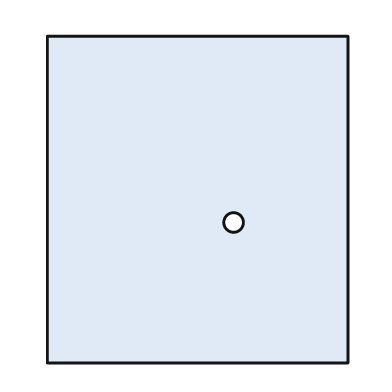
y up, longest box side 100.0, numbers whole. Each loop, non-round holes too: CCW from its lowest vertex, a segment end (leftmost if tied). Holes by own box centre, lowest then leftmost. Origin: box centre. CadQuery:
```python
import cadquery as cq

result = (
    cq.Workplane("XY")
    .moveTo(-46.0, -50.0)
    .lineTo(46.0, -50.0)
    .lineTo(46.0, 50.0)
    .lineTo(-46.0, 50.0)
    .close()
    .moveTo(11.0, -7.0)
    .circle(3.0)
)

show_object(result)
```